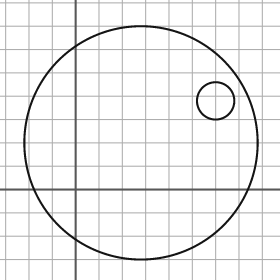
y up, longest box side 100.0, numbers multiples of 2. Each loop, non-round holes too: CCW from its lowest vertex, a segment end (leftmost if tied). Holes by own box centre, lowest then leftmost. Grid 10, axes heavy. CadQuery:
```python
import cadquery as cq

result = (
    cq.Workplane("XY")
    .moveTo(28.0, 20.0)
    .circle(50.0)
    .moveTo(60.0, 38.0)
    .circle(8.0)
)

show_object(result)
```